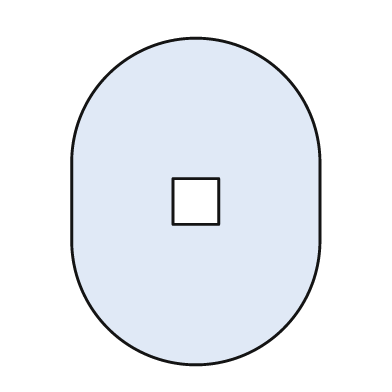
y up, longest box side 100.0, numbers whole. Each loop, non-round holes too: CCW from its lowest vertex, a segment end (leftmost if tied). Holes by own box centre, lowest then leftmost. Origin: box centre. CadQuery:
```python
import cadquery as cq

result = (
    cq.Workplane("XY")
    .moveTo(-38.0, -12.0)
    .threePointArc((0.0, -50.0), (38.0, -12.0))
    .lineTo(38.0, 12.0)
    .threePointArc((0.0, 50.0), (-38.0, 12.0))
    .close()
    .moveTo(-7.0, -7.0)
    .lineTo(7.0, -7.0)
    .lineTo(7.0, 7.0)
    .lineTo(-7.0, 7.0)
    .close()
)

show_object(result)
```